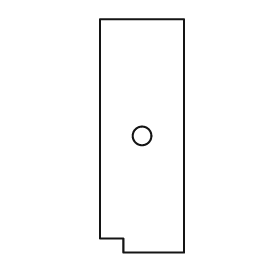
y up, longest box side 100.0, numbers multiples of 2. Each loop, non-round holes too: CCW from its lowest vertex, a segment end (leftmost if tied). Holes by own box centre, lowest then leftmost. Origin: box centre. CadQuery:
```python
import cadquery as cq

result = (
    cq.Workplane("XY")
    .moveTo(-8.0, -50.0)
    .lineTo(18.0, -50.0)
    .lineTo(18.0, 50.0)
    .lineTo(-18.0, 50.0)
    .lineTo(-18.0, -44.0)
    .lineTo(-8.0, -44.0)
    .close()
    .moveTo(0.0, 0.0)
    .circle(4.0)
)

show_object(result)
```